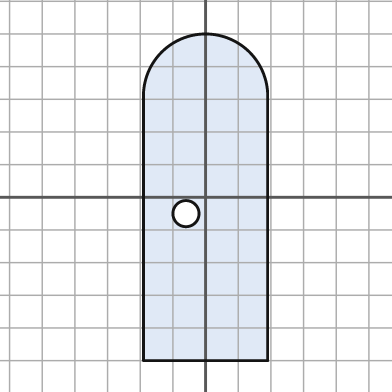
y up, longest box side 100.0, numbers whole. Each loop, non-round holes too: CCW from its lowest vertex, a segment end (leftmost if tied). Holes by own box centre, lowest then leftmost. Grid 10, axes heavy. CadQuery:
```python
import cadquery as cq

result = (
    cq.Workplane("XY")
    .moveTo(-19.0, -50.0)
    .lineTo(19.0, -50.0)
    .lineTo(19.0, 32.0)
    .threePointArc((0.0, 50.0), (-19.0, 32.0))
    .close()
    .moveTo(-6.0, -5.0)
    .circle(4.0)
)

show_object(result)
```